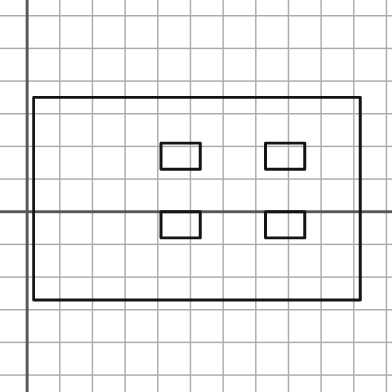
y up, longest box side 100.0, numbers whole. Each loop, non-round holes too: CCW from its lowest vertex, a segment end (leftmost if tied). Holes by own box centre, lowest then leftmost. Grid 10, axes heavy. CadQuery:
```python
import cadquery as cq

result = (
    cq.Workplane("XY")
    .moveTo(2.0, -27.0)
    .lineTo(102.0, -27.0)
    .lineTo(102.0, 35.0)
    .lineTo(2.0, 35.0)
    .close()
    .moveTo(41.0, -8.0)
    .lineTo(53.0, -8.0)
    .lineTo(53.0, 0.0)
    .lineTo(41.0, 0.0)
    .close()
    .moveTo(73.0, -8.0)
    .lineTo(85.0, -8.0)
    .lineTo(85.0, 0.0)
    .lineTo(73.0, 0.0)
    .close()
    .moveTo(41.0, 13.0)
    .lineTo(53.0, 13.0)
    .lineTo(53.0, 21.0)
    .lineTo(41.0, 21.0)
    .close()
    .moveTo(73.0, 13.0)
    .lineTo(85.0, 13.0)
    .lineTo(85.0, 21.0)
    .lineTo(73.0, 21.0)
    .close()
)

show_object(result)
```